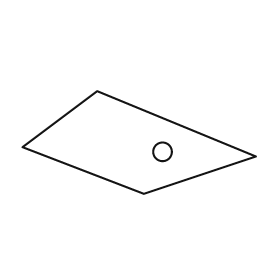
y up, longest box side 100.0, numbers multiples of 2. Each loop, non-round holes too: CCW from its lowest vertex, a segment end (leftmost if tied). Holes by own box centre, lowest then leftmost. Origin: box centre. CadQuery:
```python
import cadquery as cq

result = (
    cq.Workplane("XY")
    .moveTo(2.0, -22.0)
    .lineTo(50.0, -6.0)
    .lineTo(-18.0, 22.0)
    .lineTo(-50.0, -2.0)
    .close()
    .moveTo(10.0, -4.0)
    .circle(4.0)
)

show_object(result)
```